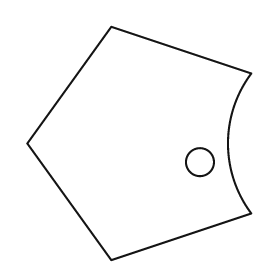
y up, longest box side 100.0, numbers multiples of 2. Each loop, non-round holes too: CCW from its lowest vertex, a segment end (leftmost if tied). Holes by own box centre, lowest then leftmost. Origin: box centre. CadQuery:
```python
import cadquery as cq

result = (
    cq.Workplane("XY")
    .moveTo(-12.0, -50.0)
    .lineTo(48.0, -30.0)
    .threePointArc((38.0, 0.0), (48.0, 30.0))
    .lineTo(-12.0, 50.0)
    .lineTo(-48.0, 0.0)
    .close()
    .moveTo(26.0, -8.0)
    .circle(6.0)
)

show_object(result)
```